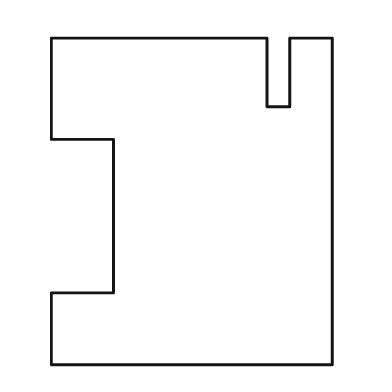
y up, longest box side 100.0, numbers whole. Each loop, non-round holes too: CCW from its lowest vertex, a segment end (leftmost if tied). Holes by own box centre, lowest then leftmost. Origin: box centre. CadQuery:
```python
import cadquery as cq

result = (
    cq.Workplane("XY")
    .moveTo(-43.0, -50.0)
    .lineTo(43.0, -50.0)
    .lineTo(43.0, 50.0)
    .lineTo(30.0, 50.0)
    .lineTo(30.0, 29.0)
    .lineTo(23.0, 29.0)
    .lineTo(23.0, 50.0)
    .lineTo(-43.0, 50.0)
    .lineTo(-43.0, 19.0)
    .lineTo(-24.0, 19.0)
    .lineTo(-24.0, -28.0)
    .lineTo(-43.0, -28.0)
    .close()
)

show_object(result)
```